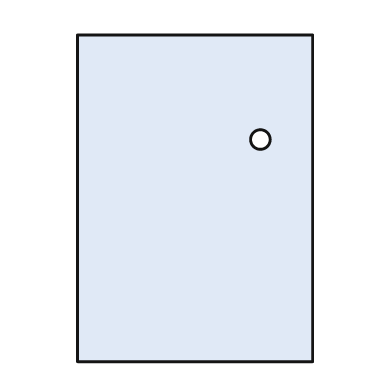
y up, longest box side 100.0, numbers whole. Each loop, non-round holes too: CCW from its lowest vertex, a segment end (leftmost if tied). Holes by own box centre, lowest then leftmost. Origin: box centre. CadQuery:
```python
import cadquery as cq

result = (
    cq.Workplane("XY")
    .moveTo(-36.0, -50.0)
    .lineTo(36.0, -50.0)
    .lineTo(36.0, 50.0)
    .lineTo(-36.0, 50.0)
    .close()
    .moveTo(20.0, 18.0)
    .circle(3.0)
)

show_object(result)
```